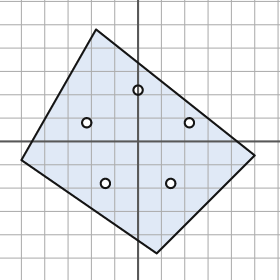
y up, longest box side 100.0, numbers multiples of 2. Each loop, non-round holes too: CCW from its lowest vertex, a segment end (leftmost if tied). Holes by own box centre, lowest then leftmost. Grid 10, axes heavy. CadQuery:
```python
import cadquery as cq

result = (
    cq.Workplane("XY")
    .moveTo(8.0, -48.0)
    .lineTo(50.0, -6.0)
    .lineTo(-18.0, 48.0)
    .lineTo(-50.0, -8.0)
    .close()
    .moveTo(-14.0, -18.0)
    .circle(2.0)
    .moveTo(14.0, -18.0)
    .circle(2.0)
    .moveTo(-22.0, 8.0)
    .circle(2.0)
    .moveTo(22.0, 8.0)
    .circle(2.0)
    .moveTo(0.0, 22.0)
    .circle(2.0)
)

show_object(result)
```